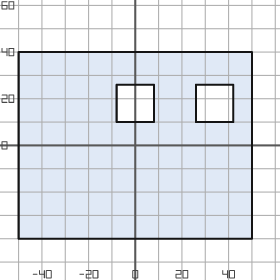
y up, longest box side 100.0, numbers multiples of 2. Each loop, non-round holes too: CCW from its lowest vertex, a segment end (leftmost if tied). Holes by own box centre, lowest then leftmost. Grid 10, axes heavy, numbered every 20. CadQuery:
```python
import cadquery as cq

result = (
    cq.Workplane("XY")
    .moveTo(-50.0, -40.0)
    .lineTo(50.0, -40.0)
    .lineTo(50.0, 40.0)
    .lineTo(-50.0, 40.0)
    .close()
    .moveTo(-8.0, 10.0)
    .lineTo(8.0, 10.0)
    .lineTo(8.0, 26.0)
    .lineTo(-8.0, 26.0)
    .close()
    .moveTo(26.0, 10.0)
    .lineTo(42.0, 10.0)
    .lineTo(42.0, 26.0)
    .lineTo(26.0, 26.0)
    .close()
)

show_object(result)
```